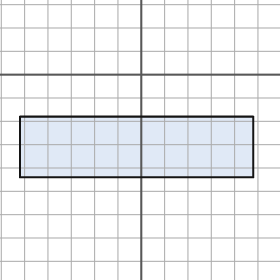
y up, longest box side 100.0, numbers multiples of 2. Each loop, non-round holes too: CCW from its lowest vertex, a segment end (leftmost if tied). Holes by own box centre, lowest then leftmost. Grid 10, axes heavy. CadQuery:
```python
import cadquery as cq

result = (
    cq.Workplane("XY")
    .moveTo(-52.0, -44.0)
    .lineTo(48.0, -44.0)
    .lineTo(48.0, -18.0)
    .lineTo(-52.0, -18.0)
    .close()
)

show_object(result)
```